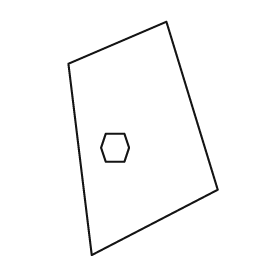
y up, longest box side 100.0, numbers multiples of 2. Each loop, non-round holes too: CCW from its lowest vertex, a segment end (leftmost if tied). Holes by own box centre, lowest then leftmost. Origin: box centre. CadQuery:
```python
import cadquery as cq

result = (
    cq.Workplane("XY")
    .moveTo(-22.0, -50.0)
    .lineTo(32.0, -22.0)
    .lineTo(10.0, 50.0)
    .lineTo(-32.0, 32.0)
    .close()
    .moveTo(-16.0, -10.0)
    .lineTo(-8.0, -10.0)
    .lineTo(-6.0, -4.0)
    .lineTo(-8.0, 2.0)
    .lineTo(-16.0, 2.0)
    .lineTo(-18.0, -4.0)
    .close()
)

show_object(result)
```